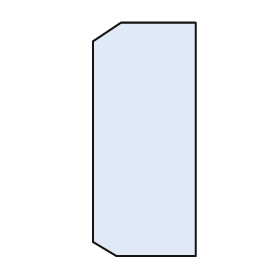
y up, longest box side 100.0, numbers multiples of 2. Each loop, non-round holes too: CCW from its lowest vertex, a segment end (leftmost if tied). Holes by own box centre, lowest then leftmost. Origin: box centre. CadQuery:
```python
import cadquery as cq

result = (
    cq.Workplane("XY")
    .moveTo(-12.0, -50.0)
    .lineTo(22.0, -50.0)
    .lineTo(22.0, 50.0)
    .lineTo(-10.0, 50.0)
    .lineTo(-22.0, 42.0)
    .lineTo(-22.0, -44.0)
    .close()
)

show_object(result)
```